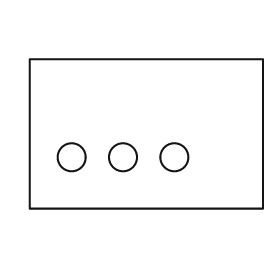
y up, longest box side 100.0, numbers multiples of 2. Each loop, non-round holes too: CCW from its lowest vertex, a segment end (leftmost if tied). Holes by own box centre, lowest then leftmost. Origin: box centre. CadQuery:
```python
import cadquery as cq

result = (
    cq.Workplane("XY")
    .moveTo(-50.0, -32.0)
    .lineTo(50.0, -32.0)
    .lineTo(50.0, 32.0)
    .lineTo(-50.0, 32.0)
    .close()
    .moveTo(-32.0, -10.0)
    .circle(6.0)
    .moveTo(-10.0, -10.0)
    .circle(6.0)
    .moveTo(12.0, -10.0)
    .circle(6.0)
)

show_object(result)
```